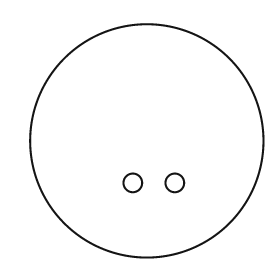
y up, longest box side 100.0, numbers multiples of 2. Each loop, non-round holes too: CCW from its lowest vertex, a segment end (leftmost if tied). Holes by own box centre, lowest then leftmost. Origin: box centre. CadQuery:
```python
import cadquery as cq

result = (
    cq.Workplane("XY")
    .moveTo(0.0, 0.0)
    .circle(50.0)
    .moveTo(-6.0, -18.0)
    .circle(4.0)
    .moveTo(12.0, -18.0)
    .circle(4.0)
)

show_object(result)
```